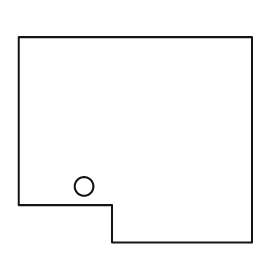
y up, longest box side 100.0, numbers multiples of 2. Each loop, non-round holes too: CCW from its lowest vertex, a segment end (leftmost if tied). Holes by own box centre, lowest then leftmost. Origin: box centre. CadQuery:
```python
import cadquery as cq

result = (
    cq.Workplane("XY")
    .moveTo(-10.0, -44.0)
    .lineTo(50.0, -44.0)
    .lineTo(50.0, 44.0)
    .lineTo(-50.0, 44.0)
    .lineTo(-50.0, -28.0)
    .lineTo(-10.0, -28.0)
    .close()
    .moveTo(-22.0, -20.0)
    .circle(4.0)
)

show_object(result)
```